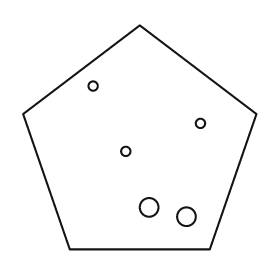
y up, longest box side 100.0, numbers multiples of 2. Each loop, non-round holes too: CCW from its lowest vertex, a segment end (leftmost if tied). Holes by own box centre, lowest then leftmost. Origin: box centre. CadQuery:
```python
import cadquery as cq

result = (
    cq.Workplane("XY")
    .moveTo(-30.0, -48.0)
    .lineTo(30.0, -48.0)
    .lineTo(50.0, 10.0)
    .lineTo(0.0, 48.0)
    .lineTo(-50.0, 10.0)
    .close()
    .moveTo(20.0, -34.0)
    .circle(4.0)
    .moveTo(4.0, -30.0)
    .circle(4.0)
    .moveTo(-6.0, -6.0)
    .circle(2.0)
    .moveTo(26.0, 6.0)
    .circle(2.0)
    .moveTo(-20.0, 22.0)
    .circle(2.0)
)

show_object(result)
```